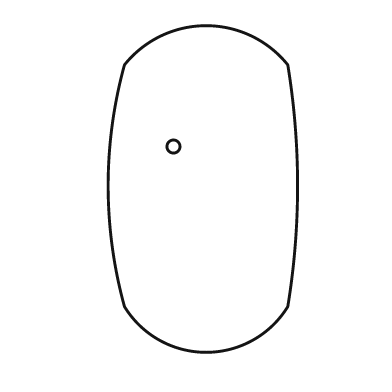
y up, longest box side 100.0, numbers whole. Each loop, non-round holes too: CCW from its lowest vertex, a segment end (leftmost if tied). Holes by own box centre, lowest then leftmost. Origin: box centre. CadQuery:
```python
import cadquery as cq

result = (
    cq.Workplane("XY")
    .moveTo(-24.0, -36.0)
    .threePointArc((1.0, -50.0), (26.0, -36.0))
    .threePointArc((29.0, 1.0), (26.0, 38.0))
    .threePointArc((1.0, 50.0), (-24.0, 38.0))
    .threePointArc((-29.0, 1.0), (-24.0, -36.0))
    .close()
    .moveTo(-9.0, 13.0)
    .circle(2.0)
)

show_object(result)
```